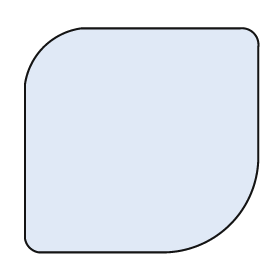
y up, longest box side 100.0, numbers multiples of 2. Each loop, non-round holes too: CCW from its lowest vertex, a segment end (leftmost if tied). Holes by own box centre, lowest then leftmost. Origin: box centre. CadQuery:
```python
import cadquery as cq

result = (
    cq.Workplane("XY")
    .moveTo(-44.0, -48.0)
    .lineTo(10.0, -48.0)
    .threePointArc((38.0, -36.0), (50.0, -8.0))
    .lineTo(50.0, 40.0)
    .threePointArc((48.0, 46.0), (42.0, 48.0))
    .lineTo(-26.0, 48.0)
    .threePointArc((-42.0, 40.0), (-50.0, 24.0))
    .lineTo(-50.0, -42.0)
    .threePointArc((-48.0, -46.0), (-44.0, -48.0))
    .close()
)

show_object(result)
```